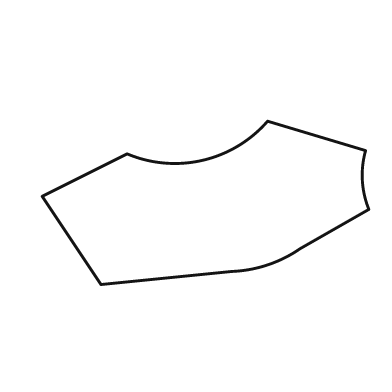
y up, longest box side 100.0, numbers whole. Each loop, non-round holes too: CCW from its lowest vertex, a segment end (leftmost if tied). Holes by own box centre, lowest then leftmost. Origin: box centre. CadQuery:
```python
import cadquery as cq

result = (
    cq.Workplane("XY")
    .moveTo(-32.0, -25.0)
    .lineTo(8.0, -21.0)
    .threePointArc((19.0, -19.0), (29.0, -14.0))
    .lineTo(50.0, -2.0)
    .threePointArc((48.0, 7.0), (49.0, 16.0))
    .lineTo(19.0, 25.0)
    .threePointArc((-1.0, 13.0), (-24.0, 15.0))
    .lineTo(-50.0, 2.0)
    .close()
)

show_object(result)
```